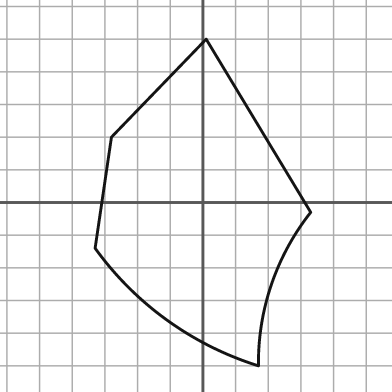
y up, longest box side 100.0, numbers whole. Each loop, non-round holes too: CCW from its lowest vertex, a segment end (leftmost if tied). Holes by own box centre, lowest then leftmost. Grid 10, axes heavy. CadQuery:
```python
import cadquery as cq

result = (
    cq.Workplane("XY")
    .moveTo(17.0, -50.0)
    .threePointArc((21.0, -25.0), (33.0, -3.0))
    .lineTo(1.0, 50.0)
    .lineTo(-28.0, 20.0)
    .lineTo(-33.0, -14.0)
    .threePointArc((-11.0, -36.0), (17.0, -50.0))
    .close()
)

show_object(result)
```